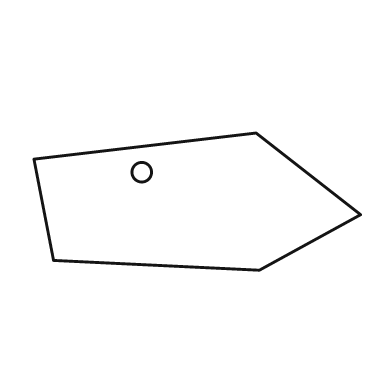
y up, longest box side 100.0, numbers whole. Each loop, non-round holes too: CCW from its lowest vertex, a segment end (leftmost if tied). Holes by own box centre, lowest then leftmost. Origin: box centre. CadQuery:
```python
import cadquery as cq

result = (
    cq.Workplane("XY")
    .moveTo(19.0, -21.0)
    .lineTo(50.0, -4.0)
    .lineTo(18.0, 21.0)
    .lineTo(-50.0, 13.0)
    .lineTo(-44.0, -18.0)
    .close()
    .moveTo(-17.0, 9.0)
    .circle(3.0)
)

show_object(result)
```